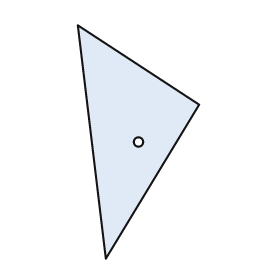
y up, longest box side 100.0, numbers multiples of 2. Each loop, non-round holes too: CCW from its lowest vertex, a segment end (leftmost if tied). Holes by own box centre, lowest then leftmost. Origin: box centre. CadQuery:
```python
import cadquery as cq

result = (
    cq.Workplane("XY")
    .moveTo(-14.0, -50.0)
    .lineTo(26.0, 16.0)
    .lineTo(-26.0, 50.0)
    .close()
    .moveTo(0.0, 0.0)
    .circle(2.0)
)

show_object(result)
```